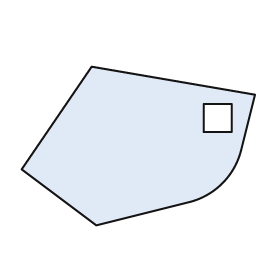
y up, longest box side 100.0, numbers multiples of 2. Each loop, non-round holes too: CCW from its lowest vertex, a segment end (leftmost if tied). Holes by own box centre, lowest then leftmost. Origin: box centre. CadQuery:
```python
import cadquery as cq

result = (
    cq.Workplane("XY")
    .moveTo(-18.0, -34.0)
    .lineTo(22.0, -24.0)
    .threePointArc((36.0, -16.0), (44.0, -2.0))
    .lineTo(50.0, 22.0)
    .lineTo(-20.0, 34.0)
    .lineTo(-50.0, -10.0)
    .close()
    .moveTo(28.0, 6.0)
    .lineTo(40.0, 6.0)
    .lineTo(40.0, 18.0)
    .lineTo(28.0, 18.0)
    .close()
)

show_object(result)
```